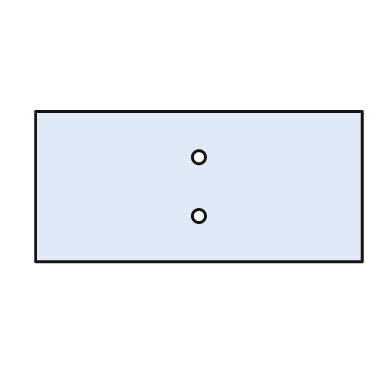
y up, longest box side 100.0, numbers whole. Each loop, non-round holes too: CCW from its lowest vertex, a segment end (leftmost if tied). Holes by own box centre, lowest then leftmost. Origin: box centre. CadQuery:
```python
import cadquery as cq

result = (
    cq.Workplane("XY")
    .moveTo(-50.0, -23.0)
    .lineTo(50.0, -23.0)
    .lineTo(50.0, 23.0)
    .lineTo(-50.0, 23.0)
    .close()
    .moveTo(0.0, -9.0)
    .circle(2.0)
    .moveTo(0.0, 9.0)
    .circle(2.0)
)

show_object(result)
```